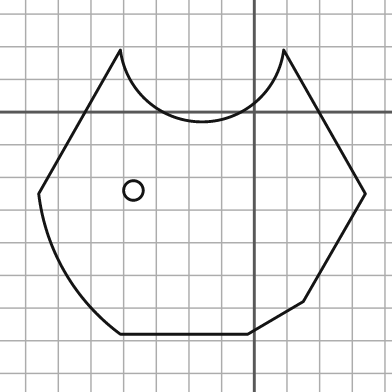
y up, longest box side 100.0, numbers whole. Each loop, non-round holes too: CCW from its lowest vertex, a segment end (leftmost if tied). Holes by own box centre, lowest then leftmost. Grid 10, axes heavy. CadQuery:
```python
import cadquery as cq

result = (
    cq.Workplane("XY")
    .moveTo(-41.0, -68.0)
    .lineTo(-2.0, -68.0)
    .lineTo(15.0, -58.0)
    .lineTo(34.0, -25.0)
    .lineTo(9.0, 19.0)
    .threePointArc((-16.0, -3.0), (-41.0, 19.0))
    .lineTo(-66.0, -25.0)
    .threePointArc((-58.0, -49.0), (-41.0, -68.0))
    .close()
    .moveTo(-37.0, -24.0)
    .circle(3.0)
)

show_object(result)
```